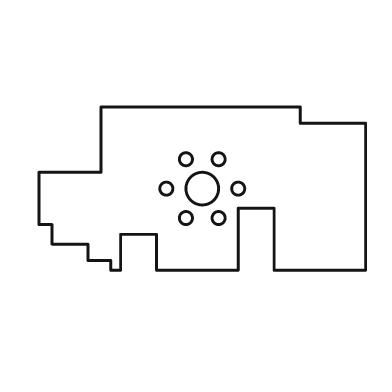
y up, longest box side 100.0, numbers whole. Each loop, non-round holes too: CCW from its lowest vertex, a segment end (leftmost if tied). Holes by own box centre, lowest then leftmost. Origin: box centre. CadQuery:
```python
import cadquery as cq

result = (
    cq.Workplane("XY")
    .moveTo(-28.0, -25.0)
    .lineTo(-25.0, -25.0)
    .lineTo(-25.0, -14.0)
    .lineTo(-14.0, -14.0)
    .lineTo(-14.0, -25.0)
    .lineTo(11.0, -25.0)
    .lineTo(11.0, -6.0)
    .lineTo(22.0, -6.0)
    .lineTo(22.0, -25.0)
    .lineTo(50.0, -25.0)
    .lineTo(50.0, 20.0)
    .lineTo(30.0, 20.0)
    .lineTo(30.0, 25.0)
    .lineTo(-31.0, 25.0)
    .lineTo(-31.0, 5.0)
    .lineTo(-50.0, 5.0)
    .lineTo(-50.0, -11.0)
    .lineTo(-46.0, -11.0)
    .lineTo(-46.0, -17.0)
    .lineTo(-35.0, -17.0)
    .lineTo(-35.0, -22.0)
    .lineTo(-28.0, -22.0)
    .close()
    .moveTo(-5.0, -9.0)
    .circle(2.0)
    .moveTo(5.0, -9.0)
    .circle(2.0)
    .moveTo(-11.0, 0.0)
    .circle(2.0)
    .moveTo(0.0, 0.0)
    .circle(5.0)
    .moveTo(11.0, 0.0)
    .circle(2.0)
    .moveTo(-5.0, 9.0)
    .circle(2.0)
    .moveTo(5.0, 9.0)
    .circle(2.0)
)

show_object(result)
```